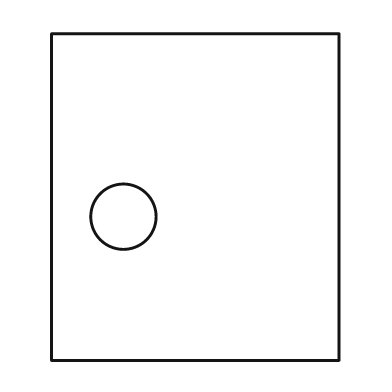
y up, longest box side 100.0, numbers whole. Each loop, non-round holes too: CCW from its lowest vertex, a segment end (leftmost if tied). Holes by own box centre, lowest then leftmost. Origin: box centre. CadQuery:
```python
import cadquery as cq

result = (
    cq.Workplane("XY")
    .moveTo(-44.0, -50.0)
    .lineTo(44.0, -50.0)
    .lineTo(44.0, 50.0)
    .lineTo(-44.0, 50.0)
    .close()
    .moveTo(-22.0, -6.0)
    .circle(10.0)
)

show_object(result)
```